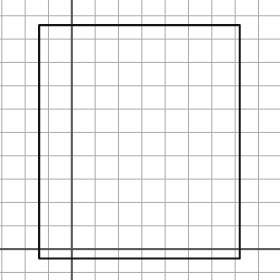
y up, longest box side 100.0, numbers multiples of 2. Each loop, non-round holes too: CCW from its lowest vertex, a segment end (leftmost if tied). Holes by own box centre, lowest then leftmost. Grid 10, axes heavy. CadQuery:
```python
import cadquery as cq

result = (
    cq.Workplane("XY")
    .moveTo(-14.0, -4.0)
    .lineTo(72.0, -4.0)
    .lineTo(72.0, 96.0)
    .lineTo(-14.0, 96.0)
    .close()
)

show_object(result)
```